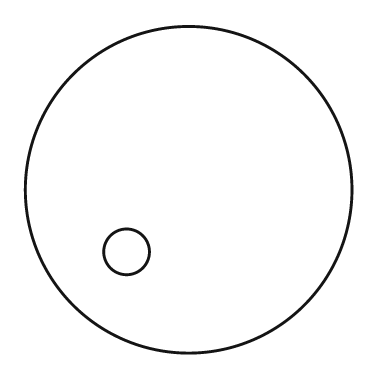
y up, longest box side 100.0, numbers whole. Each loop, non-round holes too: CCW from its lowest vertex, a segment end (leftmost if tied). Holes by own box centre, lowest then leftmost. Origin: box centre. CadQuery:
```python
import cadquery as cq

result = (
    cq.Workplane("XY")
    .moveTo(0.0, 0.0)
    .circle(50.0)
    .moveTo(-19.0, -19.0)
    .circle(7.0)
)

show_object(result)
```